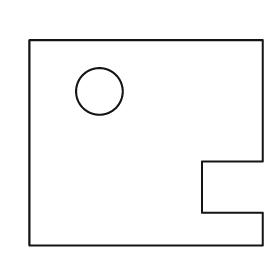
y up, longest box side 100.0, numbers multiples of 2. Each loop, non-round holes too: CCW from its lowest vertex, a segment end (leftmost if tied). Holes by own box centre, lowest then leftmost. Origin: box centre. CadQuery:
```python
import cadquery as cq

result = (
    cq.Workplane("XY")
    .moveTo(-50.0, -44.0)
    .lineTo(50.0, -44.0)
    .lineTo(50.0, -30.0)
    .lineTo(24.0, -30.0)
    .lineTo(24.0, -8.0)
    .lineTo(50.0, -8.0)
    .lineTo(50.0, 44.0)
    .lineTo(-50.0, 44.0)
    .close()
    .moveTo(-20.0, 22.0)
    .circle(10.0)
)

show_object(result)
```